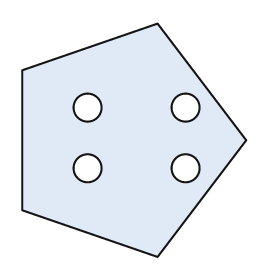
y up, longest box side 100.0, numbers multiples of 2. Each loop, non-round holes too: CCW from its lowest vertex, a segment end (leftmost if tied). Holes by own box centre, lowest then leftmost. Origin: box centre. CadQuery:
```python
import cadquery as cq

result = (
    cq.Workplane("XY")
    .moveTo(10.0, -50.0)
    .lineTo(48.0, 0.0)
    .lineTo(10.0, 50.0)
    .lineTo(-48.0, 30.0)
    .lineTo(-48.0, -30.0)
    .close()
    .moveTo(-20.0, -12.0)
    .circle(6.0)
    .moveTo(22.0, -12.0)
    .circle(6.0)
    .moveTo(-20.0, 14.0)
    .circle(6.0)
    .moveTo(22.0, 14.0)
    .circle(6.0)
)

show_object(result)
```